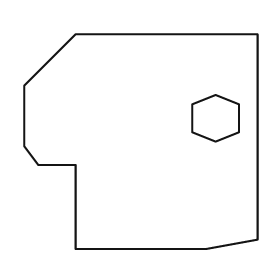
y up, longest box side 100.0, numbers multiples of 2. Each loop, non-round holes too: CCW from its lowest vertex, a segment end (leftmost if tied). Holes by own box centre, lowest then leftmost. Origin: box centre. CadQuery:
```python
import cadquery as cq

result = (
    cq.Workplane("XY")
    .moveTo(-28.0, -46.0)
    .lineTo(28.0, -46.0)
    .lineTo(50.0, -42.0)
    .lineTo(50.0, 46.0)
    .lineTo(-28.0, 46.0)
    .lineTo(-50.0, 24.0)
    .lineTo(-50.0, -2.0)
    .lineTo(-44.0, -10.0)
    .lineTo(-28.0, -10.0)
    .close()
    .moveTo(32.0, 0.0)
    .lineTo(42.0, 4.0)
    .lineTo(42.0, 16.0)
    .lineTo(32.0, 20.0)
    .lineTo(22.0, 16.0)
    .lineTo(22.0, 4.0)
    .close()
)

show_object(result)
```